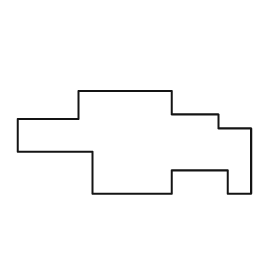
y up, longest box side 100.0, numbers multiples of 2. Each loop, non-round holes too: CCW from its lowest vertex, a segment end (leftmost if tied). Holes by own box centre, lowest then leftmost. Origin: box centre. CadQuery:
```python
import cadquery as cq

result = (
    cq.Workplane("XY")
    .moveTo(-18.0, -22.0)
    .lineTo(16.0, -22.0)
    .lineTo(16.0, -12.0)
    .lineTo(40.0, -12.0)
    .lineTo(40.0, -22.0)
    .lineTo(50.0, -22.0)
    .lineTo(50.0, 6.0)
    .lineTo(36.0, 6.0)
    .lineTo(36.0, 12.0)
    .lineTo(16.0, 12.0)
    .lineTo(16.0, 22.0)
    .lineTo(-24.0, 22.0)
    .lineTo(-24.0, 10.0)
    .lineTo(-50.0, 10.0)
    .lineTo(-50.0, -4.0)
    .lineTo(-18.0, -4.0)
    .close()
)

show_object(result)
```